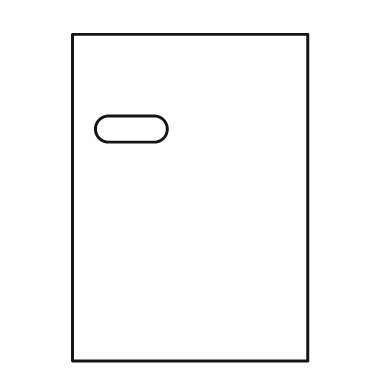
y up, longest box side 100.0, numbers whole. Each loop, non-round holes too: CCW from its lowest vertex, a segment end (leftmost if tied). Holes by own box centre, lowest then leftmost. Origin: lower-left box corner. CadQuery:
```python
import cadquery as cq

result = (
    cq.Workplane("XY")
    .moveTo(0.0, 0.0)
    .lineTo(72.0, 0.0)
    .lineTo(72.0, 100.0)
    .lineTo(0.0, 100.0)
    .close()
    .moveTo(11.0, 67.0)
    .lineTo(25.0, 67.0)
    .threePointArc((29.0, 71.0), (25.0, 75.0))
    .lineTo(11.0, 75.0)
    .threePointArc((7.0, 71.0), (11.0, 67.0))
    .close()
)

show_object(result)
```